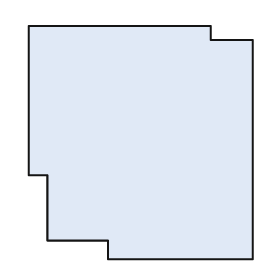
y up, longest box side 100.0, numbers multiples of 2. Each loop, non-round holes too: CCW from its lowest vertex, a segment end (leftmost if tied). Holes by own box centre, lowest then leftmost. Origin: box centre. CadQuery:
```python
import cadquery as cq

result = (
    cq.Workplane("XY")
    .moveTo(-14.0, -50.0)
    .lineTo(48.0, -50.0)
    .lineTo(48.0, 44.0)
    .lineTo(30.0, 44.0)
    .lineTo(30.0, 50.0)
    .lineTo(-48.0, 50.0)
    .lineTo(-48.0, -14.0)
    .lineTo(-40.0, -14.0)
    .lineTo(-40.0, -42.0)
    .lineTo(-14.0, -42.0)
    .close()
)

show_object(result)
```